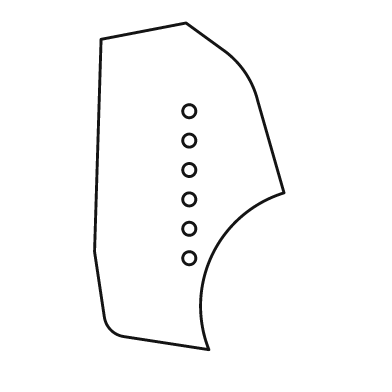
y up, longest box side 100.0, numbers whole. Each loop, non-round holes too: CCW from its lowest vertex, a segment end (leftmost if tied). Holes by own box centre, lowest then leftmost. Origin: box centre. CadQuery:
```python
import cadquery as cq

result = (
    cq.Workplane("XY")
    .moveTo(6.0, -50.0)
    .threePointArc((7.0, -21.0), (29.0, -2.0))
    .lineTo(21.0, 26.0)
    .threePointArc((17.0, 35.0), (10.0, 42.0))
    .lineTo(-1.0, 50.0)
    .lineTo(-27.0, 45.0)
    .lineTo(-29.0, -20.0)
    .lineTo(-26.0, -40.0)
    .threePointArc((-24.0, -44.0), (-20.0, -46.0))
    .close()
    .moveTo(0.0, -22.0)
    .circle(2.0)
    .moveTo(0.0, -13.0)
    .circle(2.0)
    .moveTo(0.0, -4.0)
    .circle(2.0)
    .moveTo(0.0, 5.0)
    .circle(2.0)
    .moveTo(0.0, 14.0)
    .circle(2.0)
    .moveTo(0.0, 23.0)
    .circle(2.0)
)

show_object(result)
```